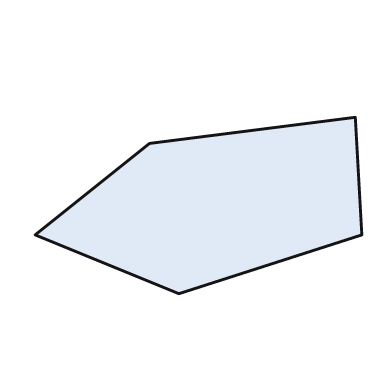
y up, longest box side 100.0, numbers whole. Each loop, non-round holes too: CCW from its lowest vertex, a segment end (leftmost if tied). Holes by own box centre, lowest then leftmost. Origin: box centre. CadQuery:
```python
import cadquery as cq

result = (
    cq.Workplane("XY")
    .moveTo(-6.0, -27.0)
    .lineTo(50.0, -9.0)
    .lineTo(48.0, 27.0)
    .lineTo(-15.0, 19.0)
    .lineTo(-50.0, -9.0)
    .close()
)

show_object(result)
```